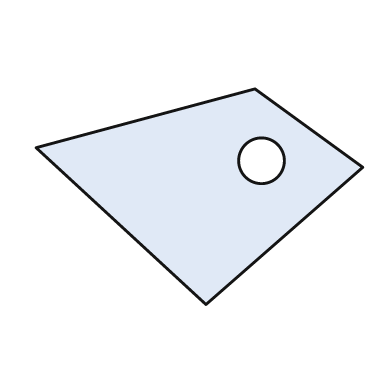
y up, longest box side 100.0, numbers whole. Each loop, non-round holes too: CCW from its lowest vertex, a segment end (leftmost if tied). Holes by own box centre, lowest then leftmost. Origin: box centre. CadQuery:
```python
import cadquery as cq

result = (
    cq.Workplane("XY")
    .moveTo(2.0, -33.0)
    .lineTo(50.0, 9.0)
    .lineTo(17.0, 33.0)
    .lineTo(-50.0, 15.0)
    .close()
    .moveTo(19.0, 11.0)
    .circle(7.0)
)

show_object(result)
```